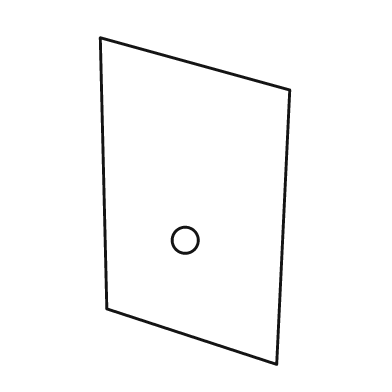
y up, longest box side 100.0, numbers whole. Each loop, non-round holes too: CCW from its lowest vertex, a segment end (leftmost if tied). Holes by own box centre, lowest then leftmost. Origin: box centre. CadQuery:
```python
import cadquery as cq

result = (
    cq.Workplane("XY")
    .moveTo(25.0, -50.0)
    .lineTo(29.0, 34.0)
    .lineTo(-29.0, 50.0)
    .lineTo(-27.0, -33.0)
    .close()
    .moveTo(-3.0, -12.0)
    .circle(4.0)
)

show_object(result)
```